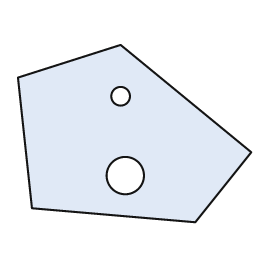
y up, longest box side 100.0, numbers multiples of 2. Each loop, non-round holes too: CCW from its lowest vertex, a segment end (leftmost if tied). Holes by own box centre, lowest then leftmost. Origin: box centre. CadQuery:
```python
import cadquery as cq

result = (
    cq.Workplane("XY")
    .moveTo(26.0, -38.0)
    .lineTo(50.0, -8.0)
    .lineTo(-6.0, 38.0)
    .lineTo(-50.0, 24.0)
    .lineTo(-44.0, -32.0)
    .close()
    .moveTo(-4.0, -18.0)
    .circle(8.0)
    .moveTo(-6.0, 16.0)
    .circle(4.0)
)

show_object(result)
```